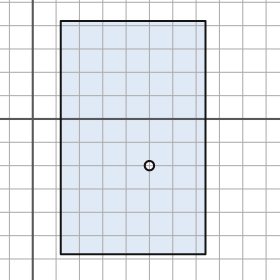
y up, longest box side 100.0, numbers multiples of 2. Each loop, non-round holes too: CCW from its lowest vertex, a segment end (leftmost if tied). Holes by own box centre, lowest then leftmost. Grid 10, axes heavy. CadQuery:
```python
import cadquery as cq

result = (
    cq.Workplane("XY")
    .moveTo(12.0, -58.0)
    .lineTo(74.0, -58.0)
    .lineTo(74.0, 42.0)
    .lineTo(12.0, 42.0)
    .close()
    .moveTo(50.0, -20.0)
    .circle(2.0)
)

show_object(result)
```